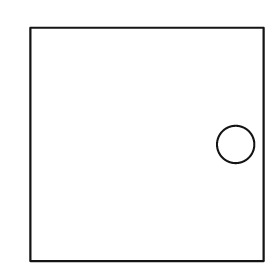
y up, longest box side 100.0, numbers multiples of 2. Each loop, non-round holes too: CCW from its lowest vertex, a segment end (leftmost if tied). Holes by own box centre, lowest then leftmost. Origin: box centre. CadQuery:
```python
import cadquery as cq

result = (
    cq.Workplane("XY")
    .moveTo(-50.0, -50.0)
    .lineTo(50.0, -50.0)
    .lineTo(50.0, 50.0)
    .lineTo(-50.0, 50.0)
    .close()
    .moveTo(38.0, 0.0)
    .circle(8.0)
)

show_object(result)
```